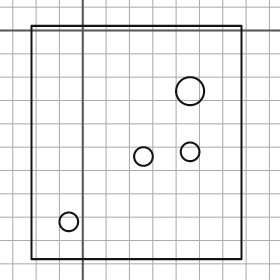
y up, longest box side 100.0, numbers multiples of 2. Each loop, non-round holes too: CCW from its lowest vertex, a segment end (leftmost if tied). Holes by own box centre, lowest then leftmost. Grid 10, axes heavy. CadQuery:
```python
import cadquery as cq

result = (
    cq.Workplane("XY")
    .moveTo(-22.0, -98.0)
    .lineTo(68.0, -98.0)
    .lineTo(68.0, 2.0)
    .lineTo(-22.0, 2.0)
    .close()
    .moveTo(-6.0, -82.0)
    .circle(4.0)
    .moveTo(26.0, -54.0)
    .circle(4.0)
    .moveTo(46.0, -52.0)
    .circle(4.0)
    .moveTo(46.0, -26.0)
    .circle(6.0)
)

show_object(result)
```